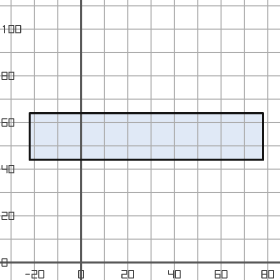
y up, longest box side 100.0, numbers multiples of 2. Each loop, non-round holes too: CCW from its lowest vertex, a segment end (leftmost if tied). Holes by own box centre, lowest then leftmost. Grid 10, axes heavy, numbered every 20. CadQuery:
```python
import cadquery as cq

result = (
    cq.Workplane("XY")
    .moveTo(-22.0, 44.0)
    .lineTo(78.0, 44.0)
    .lineTo(78.0, 64.0)
    .lineTo(-22.0, 64.0)
    .close()
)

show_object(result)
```